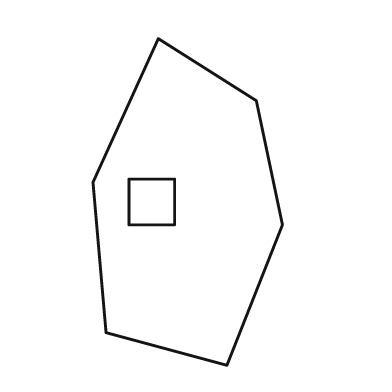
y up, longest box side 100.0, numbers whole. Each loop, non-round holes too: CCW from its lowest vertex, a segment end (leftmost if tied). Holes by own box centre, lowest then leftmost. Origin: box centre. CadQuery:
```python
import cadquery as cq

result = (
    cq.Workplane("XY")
    .moveTo(12.0, -50.0)
    .lineTo(29.0, -7.0)
    .lineTo(21.0, 31.0)
    .lineTo(-9.0, 50.0)
    .lineTo(-29.0, 6.0)
    .lineTo(-25.0, -40.0)
    .close()
    .moveTo(-18.0, -7.0)
    .lineTo(-4.0, -7.0)
    .lineTo(-4.0, 7.0)
    .lineTo(-18.0, 7.0)
    .close()
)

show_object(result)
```